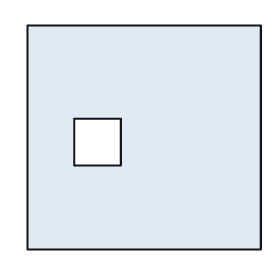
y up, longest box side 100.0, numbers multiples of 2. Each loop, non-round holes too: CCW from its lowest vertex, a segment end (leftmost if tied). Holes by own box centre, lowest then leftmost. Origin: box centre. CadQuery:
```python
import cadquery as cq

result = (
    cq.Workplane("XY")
    .moveTo(-50.0, -48.0)
    .lineTo(50.0, -48.0)
    .lineTo(50.0, 48.0)
    .lineTo(-50.0, 48.0)
    .close()
    .moveTo(-30.0, -12.0)
    .lineTo(-10.0, -12.0)
    .lineTo(-10.0, 8.0)
    .lineTo(-30.0, 8.0)
    .close()
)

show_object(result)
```